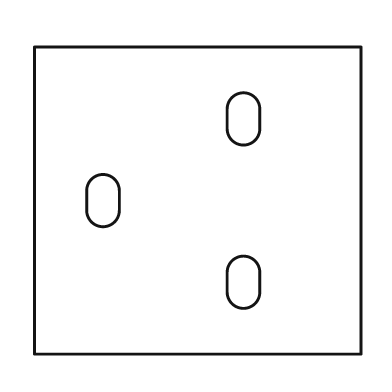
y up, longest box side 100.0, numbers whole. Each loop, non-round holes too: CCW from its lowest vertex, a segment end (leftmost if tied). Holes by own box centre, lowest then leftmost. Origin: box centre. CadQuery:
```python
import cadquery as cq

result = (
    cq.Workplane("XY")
    .moveTo(-50.0, -47.0)
    .lineTo(50.0, -47.0)
    .lineTo(50.0, 47.0)
    .lineTo(-50.0, 47.0)
    .close()
    .moveTo(9.0, -28.0)
    .threePointArc((14.0, -33.0), (19.0, -28.0))
    .lineTo(19.0, -22.0)
    .threePointArc((14.0, -17.0), (9.0, -22.0))
    .close()
    .moveTo(-34.0, -3.0)
    .threePointArc((-29.0, -8.0), (-24.0, -3.0))
    .lineTo(-24.0, 3.0)
    .threePointArc((-29.0, 8.0), (-34.0, 3.0))
    .close()
    .moveTo(9.0, 22.0)
    .threePointArc((14.0, 17.0), (19.0, 22.0))
    .lineTo(19.0, 28.0)
    .threePointArc((14.0, 33.0), (9.0, 28.0))
    .close()
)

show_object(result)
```